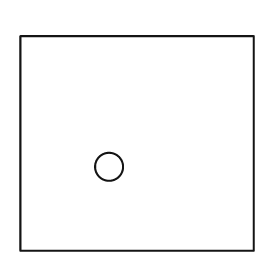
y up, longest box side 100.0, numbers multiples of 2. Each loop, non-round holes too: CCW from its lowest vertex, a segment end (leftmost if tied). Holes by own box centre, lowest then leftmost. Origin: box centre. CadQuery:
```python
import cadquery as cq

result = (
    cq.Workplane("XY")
    .moveTo(-50.0, -46.0)
    .lineTo(50.0, -46.0)
    .lineTo(50.0, 46.0)
    .lineTo(-50.0, 46.0)
    .close()
    .moveTo(-12.0, -10.0)
    .circle(6.0)
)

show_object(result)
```